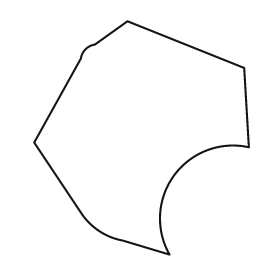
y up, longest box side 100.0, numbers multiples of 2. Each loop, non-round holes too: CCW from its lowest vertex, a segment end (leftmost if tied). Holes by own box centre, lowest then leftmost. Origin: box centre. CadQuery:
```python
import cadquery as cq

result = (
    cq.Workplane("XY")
    .moveTo(12.0, -50.0)
    .threePointArc((14.0, -16.0), (46.0, -4.0))
    .lineTo(44.0, 30.0)
    .lineTo(-6.0, 50.0)
    .lineTo(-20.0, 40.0)
    .threePointArc((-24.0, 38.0), (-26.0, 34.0))
    .lineTo(-46.0, -2.0)
    .lineTo(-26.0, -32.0)
    .threePointArc((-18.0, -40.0), (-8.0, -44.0))
    .close()
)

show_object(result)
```